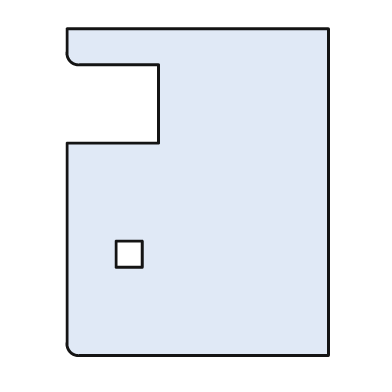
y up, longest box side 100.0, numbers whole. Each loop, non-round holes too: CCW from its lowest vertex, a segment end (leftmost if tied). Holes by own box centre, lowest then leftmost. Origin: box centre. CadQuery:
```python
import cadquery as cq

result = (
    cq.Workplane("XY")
    .moveTo(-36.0, -50.0)
    .lineTo(40.0, -50.0)
    .lineTo(40.0, 50.0)
    .lineTo(-40.0, 50.0)
    .lineTo(-40.0, 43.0)
    .threePointArc((-39.0, 40.0), (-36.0, 39.0))
    .lineTo(-12.0, 39.0)
    .lineTo(-12.0, 15.0)
    .lineTo(-40.0, 15.0)
    .lineTo(-40.0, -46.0)
    .threePointArc((-39.0, -49.0), (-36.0, -50.0))
    .close()
    .moveTo(-25.0, -23.0)
    .lineTo(-17.0, -23.0)
    .lineTo(-17.0, -15.0)
    .lineTo(-25.0, -15.0)
    .close()
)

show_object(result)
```